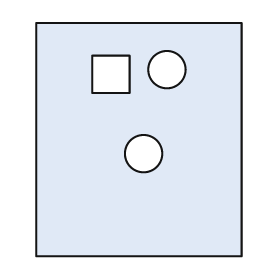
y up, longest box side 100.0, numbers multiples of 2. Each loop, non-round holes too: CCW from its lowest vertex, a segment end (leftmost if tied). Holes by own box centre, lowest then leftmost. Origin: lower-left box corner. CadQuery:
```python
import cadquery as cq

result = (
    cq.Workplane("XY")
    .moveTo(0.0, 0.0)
    .lineTo(88.0, 0.0)
    .lineTo(88.0, 100.0)
    .lineTo(0.0, 100.0)
    .close()
    .moveTo(46.0, 44.0)
    .circle(8.0)
    .moveTo(24.0, 70.0)
    .lineTo(40.0, 70.0)
    .lineTo(40.0, 86.0)
    .lineTo(24.0, 86.0)
    .close()
    .moveTo(56.0, 80.0)
    .circle(8.0)
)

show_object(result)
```